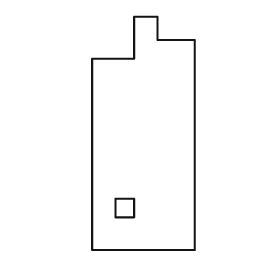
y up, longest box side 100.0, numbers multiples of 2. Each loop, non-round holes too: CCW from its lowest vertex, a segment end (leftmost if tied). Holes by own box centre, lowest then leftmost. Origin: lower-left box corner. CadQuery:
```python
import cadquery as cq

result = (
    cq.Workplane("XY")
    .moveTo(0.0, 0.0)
    .lineTo(44.0, 0.0)
    .lineTo(44.0, 90.0)
    .lineTo(28.0, 90.0)
    .lineTo(28.0, 100.0)
    .lineTo(18.0, 100.0)
    .lineTo(18.0, 82.0)
    .lineTo(0.0, 82.0)
    .close()
    .moveTo(10.0, 14.0)
    .lineTo(18.0, 14.0)
    .lineTo(18.0, 22.0)
    .lineTo(10.0, 22.0)
    .close()
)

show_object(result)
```